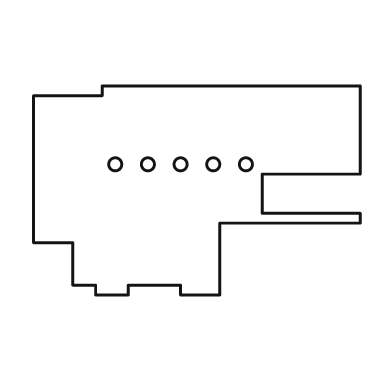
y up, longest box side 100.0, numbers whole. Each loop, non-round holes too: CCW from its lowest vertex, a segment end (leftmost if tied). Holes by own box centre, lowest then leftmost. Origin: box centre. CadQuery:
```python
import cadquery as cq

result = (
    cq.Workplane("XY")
    .moveTo(-31.0, -32.0)
    .lineTo(-21.0, -32.0)
    .lineTo(-21.0, -29.0)
    .lineTo(-5.0, -29.0)
    .lineTo(-5.0, -32.0)
    .lineTo(7.0, -32.0)
    .lineTo(7.0, -10.0)
    .lineTo(50.0, -10.0)
    .lineTo(50.0, -7.0)
    .lineTo(20.0, -7.0)
    .lineTo(20.0, 5.0)
    .lineTo(50.0, 5.0)
    .lineTo(50.0, 32.0)
    .lineTo(-29.0, 32.0)
    .lineTo(-29.0, 29.0)
    .lineTo(-50.0, 29.0)
    .lineTo(-50.0, -16.0)
    .lineTo(-38.0, -16.0)
    .lineTo(-38.0, -29.0)
    .lineTo(-31.0, -29.0)
    .close()
    .moveTo(-25.0, 8.0)
    .circle(2.0)
    .moveTo(-15.0, 8.0)
    .circle(2.0)
    .moveTo(-5.0, 8.0)
    .circle(2.0)
    .moveTo(5.0, 8.0)
    .circle(2.0)
    .moveTo(15.0, 8.0)
    .circle(2.0)
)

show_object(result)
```